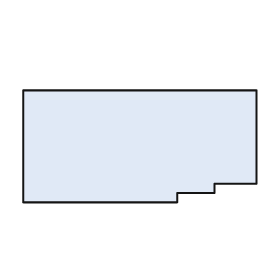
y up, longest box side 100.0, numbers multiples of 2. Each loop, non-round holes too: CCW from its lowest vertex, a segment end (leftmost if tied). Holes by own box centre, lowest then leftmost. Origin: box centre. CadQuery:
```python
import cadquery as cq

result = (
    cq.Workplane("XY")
    .moveTo(-50.0, -24.0)
    .lineTo(16.0, -24.0)
    .lineTo(16.0, -20.0)
    .lineTo(32.0, -20.0)
    .lineTo(32.0, -16.0)
    .lineTo(50.0, -16.0)
    .lineTo(50.0, 24.0)
    .lineTo(-50.0, 24.0)
    .close()
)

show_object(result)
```